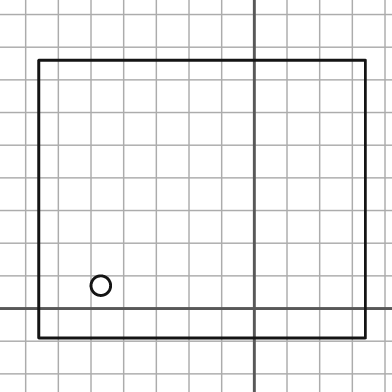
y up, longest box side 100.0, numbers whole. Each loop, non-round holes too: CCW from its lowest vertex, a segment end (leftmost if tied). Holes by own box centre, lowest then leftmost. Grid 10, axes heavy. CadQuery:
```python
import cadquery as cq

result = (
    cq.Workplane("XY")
    .moveTo(-66.0, -9.0)
    .lineTo(34.0, -9.0)
    .lineTo(34.0, 76.0)
    .lineTo(-66.0, 76.0)
    .close()
    .moveTo(-47.0, 7.0)
    .circle(3.0)
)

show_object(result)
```